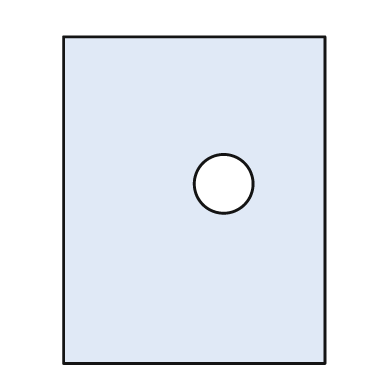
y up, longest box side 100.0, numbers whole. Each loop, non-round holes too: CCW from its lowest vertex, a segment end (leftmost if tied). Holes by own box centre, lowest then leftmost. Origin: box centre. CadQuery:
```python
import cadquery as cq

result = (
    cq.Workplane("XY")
    .moveTo(-40.0, -50.0)
    .lineTo(40.0, -50.0)
    .lineTo(40.0, 50.0)
    .lineTo(-40.0, 50.0)
    .close()
    .moveTo(9.0, 5.0)
    .circle(9.0)
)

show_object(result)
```